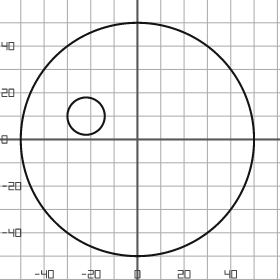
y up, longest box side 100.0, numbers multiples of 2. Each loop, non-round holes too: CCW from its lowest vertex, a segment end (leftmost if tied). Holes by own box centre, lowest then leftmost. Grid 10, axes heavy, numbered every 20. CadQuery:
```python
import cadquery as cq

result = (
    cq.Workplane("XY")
    .moveTo(0.0, 0.0)
    .circle(50.0)
    .moveTo(-22.0, 10.0)
    .circle(8.0)
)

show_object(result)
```